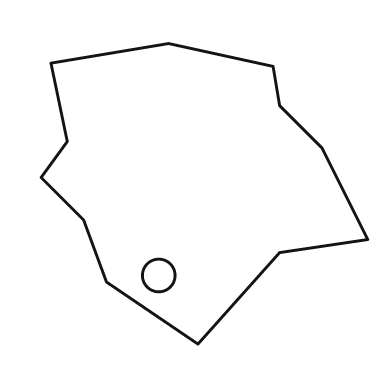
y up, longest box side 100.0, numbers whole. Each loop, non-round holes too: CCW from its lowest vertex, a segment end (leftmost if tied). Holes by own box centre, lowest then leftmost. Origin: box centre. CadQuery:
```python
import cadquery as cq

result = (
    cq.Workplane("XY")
    .moveTo(-2.0, -46.0)
    .lineTo(23.0, -18.0)
    .lineTo(50.0, -14.0)
    .lineTo(36.0, 14.0)
    .lineTo(23.0, 27.0)
    .lineTo(21.0, 39.0)
    .lineTo(-11.0, 46.0)
    .lineTo(-47.0, 40.0)
    .lineTo(-42.0, 16.0)
    .lineTo(-50.0, 5.0)
    .lineTo(-37.0, -8.0)
    .lineTo(-30.0, -27.0)
    .close()
    .moveTo(-14.0, -25.0)
    .circle(5.0)
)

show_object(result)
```